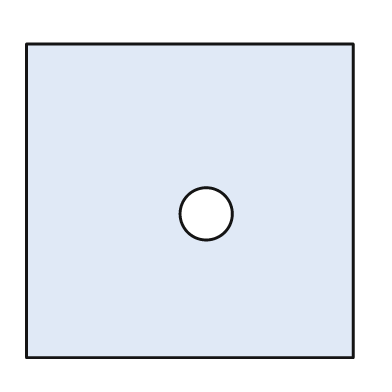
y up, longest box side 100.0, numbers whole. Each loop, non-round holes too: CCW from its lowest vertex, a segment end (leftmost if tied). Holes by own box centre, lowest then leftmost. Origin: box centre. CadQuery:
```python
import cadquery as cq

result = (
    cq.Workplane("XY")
    .moveTo(-50.0, -48.0)
    .lineTo(50.0, -48.0)
    .lineTo(50.0, 48.0)
    .lineTo(-50.0, 48.0)
    .close()
    .moveTo(5.0, -4.0)
    .circle(8.0)
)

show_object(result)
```